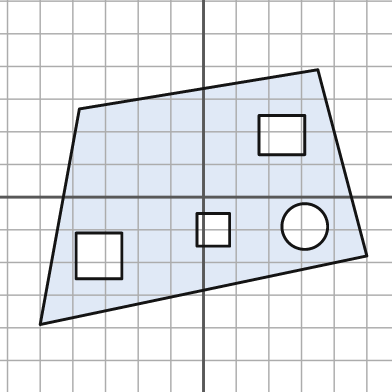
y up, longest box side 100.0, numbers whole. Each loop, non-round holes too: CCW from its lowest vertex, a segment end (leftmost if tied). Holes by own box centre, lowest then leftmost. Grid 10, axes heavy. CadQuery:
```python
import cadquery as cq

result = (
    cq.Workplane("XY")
    .moveTo(-50.0, -39.0)
    .lineTo(50.0, -18.0)
    .lineTo(35.0, 39.0)
    .lineTo(-38.0, 27.0)
    .close()
    .moveTo(-39.0, -25.0)
    .lineTo(-25.0, -25.0)
    .lineTo(-25.0, -11.0)
    .lineTo(-39.0, -11.0)
    .close()
    .moveTo(-2.0, -15.0)
    .lineTo(8.0, -15.0)
    .lineTo(8.0, -5.0)
    .lineTo(-2.0, -5.0)
    .close()
    .moveTo(31.0, -9.0)
    .circle(7.0)
    .moveTo(17.0, 13.0)
    .lineTo(31.0, 13.0)
    .lineTo(31.0, 25.0)
    .lineTo(17.0, 25.0)
    .close()
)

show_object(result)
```